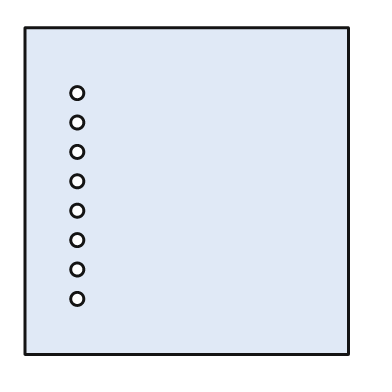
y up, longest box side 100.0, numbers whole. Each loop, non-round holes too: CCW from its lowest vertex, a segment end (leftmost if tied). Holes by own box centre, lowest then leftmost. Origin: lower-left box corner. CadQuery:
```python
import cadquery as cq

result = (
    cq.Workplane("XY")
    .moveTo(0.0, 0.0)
    .lineTo(99.0, 0.0)
    .lineTo(99.0, 100.0)
    .lineTo(0.0, 100.0)
    .close()
    .moveTo(16.0, 17.0)
    .circle(2.0)
    .moveTo(16.0, 26.0)
    .circle(2.0)
    .moveTo(16.0, 35.0)
    .circle(2.0)
    .moveTo(16.0, 44.0)
    .circle(2.0)
    .moveTo(16.0, 53.0)
    .circle(2.0)
    .moveTo(16.0, 62.0)
    .circle(2.0)
    .moveTo(16.0, 71.0)
    .circle(2.0)
    .moveTo(16.0, 80.0)
    .circle(2.0)
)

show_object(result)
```